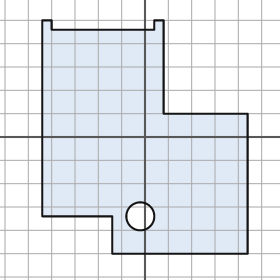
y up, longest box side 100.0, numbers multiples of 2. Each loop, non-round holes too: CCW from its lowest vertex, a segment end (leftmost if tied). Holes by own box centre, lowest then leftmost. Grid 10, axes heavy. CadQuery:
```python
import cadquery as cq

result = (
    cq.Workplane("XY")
    .moveTo(-14.0, -50.0)
    .lineTo(44.0, -50.0)
    .lineTo(44.0, 10.0)
    .lineTo(8.0, 10.0)
    .lineTo(8.0, 50.0)
    .lineTo(4.0, 50.0)
    .lineTo(4.0, 46.0)
    .lineTo(-40.0, 46.0)
    .lineTo(-40.0, 50.0)
    .lineTo(-44.0, 50.0)
    .lineTo(-44.0, -34.0)
    .lineTo(-14.0, -34.0)
    .close()
    .moveTo(-2.0, -34.0)
    .circle(6.0)
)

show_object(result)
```